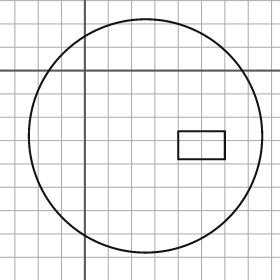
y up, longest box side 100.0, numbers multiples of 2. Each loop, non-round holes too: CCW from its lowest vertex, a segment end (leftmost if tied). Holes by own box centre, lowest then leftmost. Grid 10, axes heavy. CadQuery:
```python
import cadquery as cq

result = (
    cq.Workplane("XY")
    .moveTo(26.0, -28.0)
    .circle(50.0)
    .moveTo(40.0, -38.0)
    .lineTo(60.0, -38.0)
    .lineTo(60.0, -26.0)
    .lineTo(40.0, -26.0)
    .close()
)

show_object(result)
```